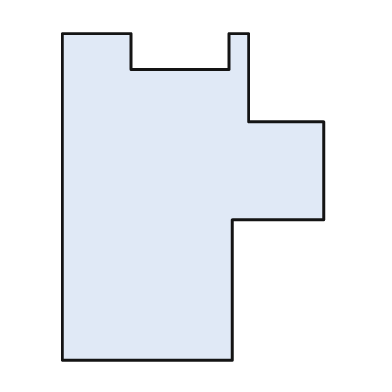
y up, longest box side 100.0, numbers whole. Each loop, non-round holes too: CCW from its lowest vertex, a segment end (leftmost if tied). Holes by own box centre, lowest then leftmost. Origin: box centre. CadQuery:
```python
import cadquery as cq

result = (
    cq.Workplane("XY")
    .moveTo(-40.0, -50.0)
    .lineTo(12.0, -50.0)
    .lineTo(12.0, -7.0)
    .lineTo(40.0, -7.0)
    .lineTo(40.0, 23.0)
    .lineTo(17.0, 23.0)
    .lineTo(17.0, 50.0)
    .lineTo(11.0, 50.0)
    .lineTo(11.0, 39.0)
    .lineTo(-19.0, 39.0)
    .lineTo(-19.0, 50.0)
    .lineTo(-40.0, 50.0)
    .close()
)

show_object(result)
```